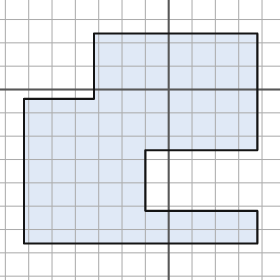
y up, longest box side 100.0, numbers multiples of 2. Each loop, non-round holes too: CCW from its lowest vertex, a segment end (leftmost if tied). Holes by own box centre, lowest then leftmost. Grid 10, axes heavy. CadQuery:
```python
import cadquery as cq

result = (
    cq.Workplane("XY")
    .moveTo(-62.0, -66.0)
    .lineTo(38.0, -66.0)
    .lineTo(38.0, -52.0)
    .lineTo(-10.0, -52.0)
    .lineTo(-10.0, -26.0)
    .lineTo(38.0, -26.0)
    .lineTo(38.0, 24.0)
    .lineTo(-32.0, 24.0)
    .lineTo(-32.0, -4.0)
    .lineTo(-62.0, -4.0)
    .close()
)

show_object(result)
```